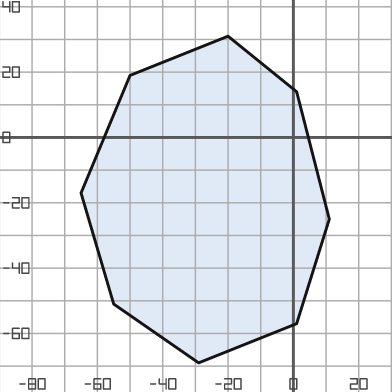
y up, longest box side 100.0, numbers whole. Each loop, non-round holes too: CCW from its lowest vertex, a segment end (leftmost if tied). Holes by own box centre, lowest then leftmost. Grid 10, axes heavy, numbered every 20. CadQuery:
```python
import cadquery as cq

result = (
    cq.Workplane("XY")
    .moveTo(-29.0, -69.0)
    .lineTo(1.0, -57.0)
    .lineTo(11.0, -25.0)
    .lineTo(1.0, 14.0)
    .lineTo(-20.0, 31.0)
    .lineTo(-50.0, 19.0)
    .lineTo(-65.0, -17.0)
    .lineTo(-55.0, -51.0)
    .close()
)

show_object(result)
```